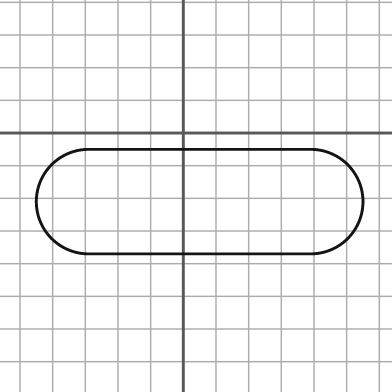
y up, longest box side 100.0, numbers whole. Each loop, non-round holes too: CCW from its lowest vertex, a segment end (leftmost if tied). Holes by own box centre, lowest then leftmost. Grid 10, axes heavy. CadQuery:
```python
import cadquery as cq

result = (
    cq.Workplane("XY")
    .moveTo(-29.0, -37.0)
    .lineTo(39.0, -37.0)
    .threePointArc((55.0, -21.0), (39.0, -5.0))
    .lineTo(-29.0, -5.0)
    .threePointArc((-45.0, -21.0), (-29.0, -37.0))
    .close()
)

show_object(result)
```